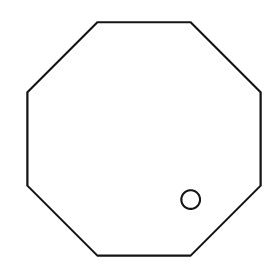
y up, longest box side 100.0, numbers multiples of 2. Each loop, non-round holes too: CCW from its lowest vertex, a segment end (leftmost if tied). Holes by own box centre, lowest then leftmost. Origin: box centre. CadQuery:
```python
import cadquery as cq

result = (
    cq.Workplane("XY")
    .moveTo(-20.0, -50.0)
    .lineTo(20.0, -50.0)
    .lineTo(50.0, -20.0)
    .lineTo(50.0, 20.0)
    .lineTo(20.0, 50.0)
    .lineTo(-20.0, 50.0)
    .lineTo(-50.0, 20.0)
    .lineTo(-50.0, -20.0)
    .close()
    .moveTo(20.0, -26.0)
    .circle(4.0)
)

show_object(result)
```